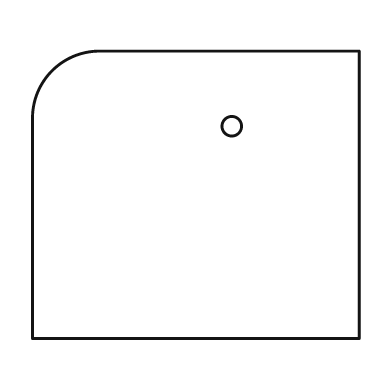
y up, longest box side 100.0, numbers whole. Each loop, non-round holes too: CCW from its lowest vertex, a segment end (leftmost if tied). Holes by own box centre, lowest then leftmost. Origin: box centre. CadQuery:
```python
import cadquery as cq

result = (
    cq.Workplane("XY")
    .moveTo(-50.0, -44.0)
    .lineTo(50.0, -44.0)
    .lineTo(50.0, 44.0)
    .lineTo(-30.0, 44.0)
    .threePointArc((-44.0, 38.0), (-50.0, 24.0))
    .close()
    .moveTo(11.0, 21.0)
    .circle(3.0)
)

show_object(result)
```